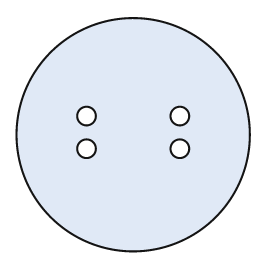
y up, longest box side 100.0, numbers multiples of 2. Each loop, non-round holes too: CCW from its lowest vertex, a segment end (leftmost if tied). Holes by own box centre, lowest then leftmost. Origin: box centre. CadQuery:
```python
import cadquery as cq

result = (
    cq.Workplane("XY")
    .moveTo(0.0, 0.0)
    .circle(50.0)
    .moveTo(-20.0, -6.0)
    .circle(4.0)
    .moveTo(20.0, -6.0)
    .circle(4.0)
    .moveTo(-20.0, 8.0)
    .circle(4.0)
    .moveTo(20.0, 8.0)
    .circle(4.0)
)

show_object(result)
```